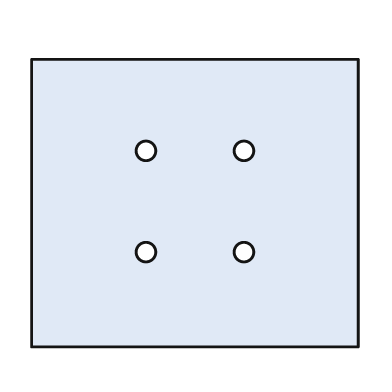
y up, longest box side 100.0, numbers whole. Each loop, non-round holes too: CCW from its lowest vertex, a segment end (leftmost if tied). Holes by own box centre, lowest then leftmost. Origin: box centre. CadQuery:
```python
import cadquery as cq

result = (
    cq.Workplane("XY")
    .moveTo(-50.0, -44.0)
    .lineTo(50.0, -44.0)
    .lineTo(50.0, 44.0)
    .lineTo(-50.0, 44.0)
    .close()
    .moveTo(-15.0, -15.0)
    .circle(3.0)
    .moveTo(15.0, -15.0)
    .circle(3.0)
    .moveTo(-15.0, 16.0)
    .circle(3.0)
    .moveTo(15.0, 16.0)
    .circle(3.0)
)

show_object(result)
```